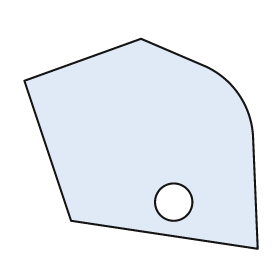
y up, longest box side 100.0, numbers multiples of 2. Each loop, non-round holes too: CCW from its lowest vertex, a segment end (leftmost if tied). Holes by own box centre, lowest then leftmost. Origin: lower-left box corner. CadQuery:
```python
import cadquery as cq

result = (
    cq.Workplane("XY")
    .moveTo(100.0, 0.0)
    .lineTo(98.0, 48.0)
    .threePointArc((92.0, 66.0), (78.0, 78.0))
    .lineTo(50.0, 90.0)
    .lineTo(0.0, 72.0)
    .lineTo(20.0, 12.0)
    .close()
    .moveTo(64.0, 20.0)
    .circle(8.0)
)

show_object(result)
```